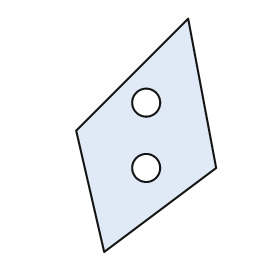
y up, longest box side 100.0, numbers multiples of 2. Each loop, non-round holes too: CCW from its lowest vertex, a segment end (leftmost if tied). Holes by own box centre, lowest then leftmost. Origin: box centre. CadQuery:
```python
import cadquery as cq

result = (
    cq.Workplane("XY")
    .moveTo(-18.0, -50.0)
    .lineTo(30.0, -14.0)
    .lineTo(18.0, 50.0)
    .lineTo(-30.0, 2.0)
    .close()
    .moveTo(0.0, -14.0)
    .circle(6.0)
    .moveTo(0.0, 14.0)
    .circle(6.0)
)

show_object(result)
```